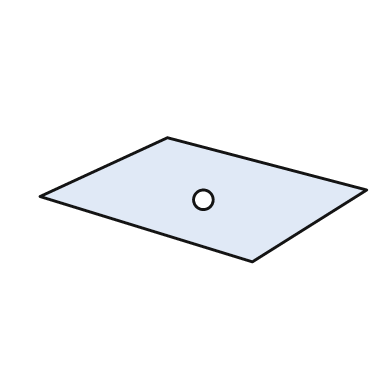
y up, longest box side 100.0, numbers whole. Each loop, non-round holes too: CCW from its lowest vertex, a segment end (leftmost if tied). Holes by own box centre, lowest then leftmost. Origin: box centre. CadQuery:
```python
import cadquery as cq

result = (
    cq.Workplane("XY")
    .moveTo(15.0, -19.0)
    .lineTo(50.0, 3.0)
    .lineTo(-11.0, 19.0)
    .lineTo(-50.0, 1.0)
    .close()
    .moveTo(0.0, 0.0)
    .circle(3.0)
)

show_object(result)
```